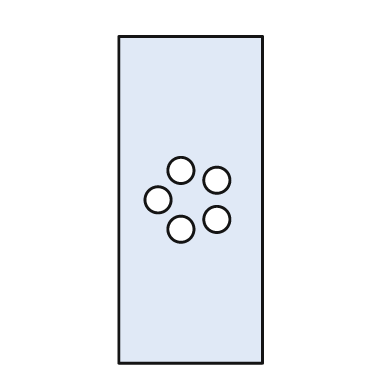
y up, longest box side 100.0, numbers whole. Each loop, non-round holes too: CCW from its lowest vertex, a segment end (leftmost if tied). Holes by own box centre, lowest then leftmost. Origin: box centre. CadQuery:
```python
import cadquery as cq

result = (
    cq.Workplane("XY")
    .moveTo(-22.0, -50.0)
    .lineTo(22.0, -50.0)
    .lineTo(22.0, 50.0)
    .lineTo(-22.0, 50.0)
    .close()
    .moveTo(-3.0, -9.0)
    .circle(4.0)
    .moveTo(8.0, -6.0)
    .circle(4.0)
    .moveTo(-10.0, 0.0)
    .circle(4.0)
    .moveTo(8.0, 6.0)
    .circle(4.0)
    .moveTo(-3.0, 9.0)
    .circle(4.0)
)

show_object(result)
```